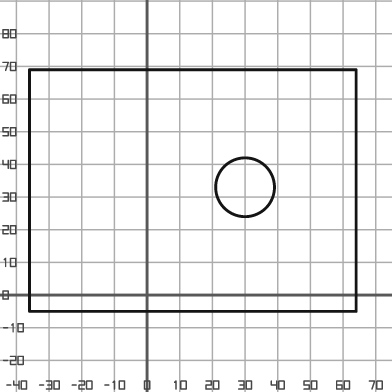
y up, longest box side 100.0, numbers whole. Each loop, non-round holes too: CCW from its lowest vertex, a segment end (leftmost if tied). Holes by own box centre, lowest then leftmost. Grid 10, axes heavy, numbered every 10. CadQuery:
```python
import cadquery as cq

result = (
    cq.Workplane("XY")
    .moveTo(-36.0, -5.0)
    .lineTo(64.0, -5.0)
    .lineTo(64.0, 69.0)
    .lineTo(-36.0, 69.0)
    .close()
    .moveTo(30.0, 33.0)
    .circle(9.0)
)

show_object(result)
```